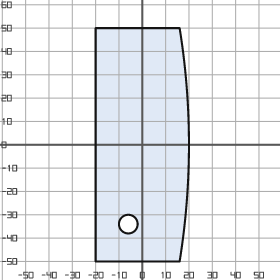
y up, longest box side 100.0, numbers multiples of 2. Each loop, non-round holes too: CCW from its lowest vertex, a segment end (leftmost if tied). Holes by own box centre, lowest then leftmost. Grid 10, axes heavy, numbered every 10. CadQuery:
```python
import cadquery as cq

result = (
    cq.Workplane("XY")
    .moveTo(-20.0, -50.0)
    .lineTo(16.0, -50.0)
    .threePointArc((20.0, 0.0), (16.0, 50.0))
    .lineTo(-20.0, 50.0)
    .close()
    .moveTo(-6.0, -34.0)
    .circle(4.0)
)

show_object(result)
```